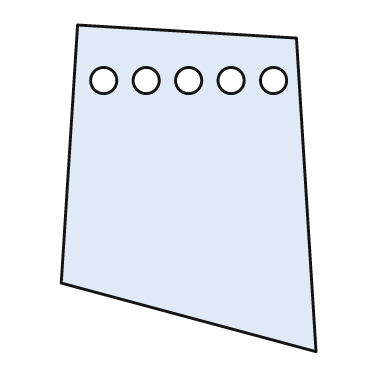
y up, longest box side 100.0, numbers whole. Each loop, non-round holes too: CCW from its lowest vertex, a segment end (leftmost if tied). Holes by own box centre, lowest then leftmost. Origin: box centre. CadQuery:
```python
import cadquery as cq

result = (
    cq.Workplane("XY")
    .moveTo(39.0, -50.0)
    .lineTo(33.0, 46.0)
    .lineTo(-34.0, 50.0)
    .lineTo(-39.0, -29.0)
    .close()
    .moveTo(-26.0, 33.0)
    .circle(4.0)
    .moveTo(-13.0, 33.0)
    .circle(4.0)
    .moveTo(0.0, 33.0)
    .circle(4.0)
    .moveTo(13.0, 33.0)
    .circle(4.0)
    .moveTo(26.0, 33.0)
    .circle(4.0)
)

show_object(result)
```